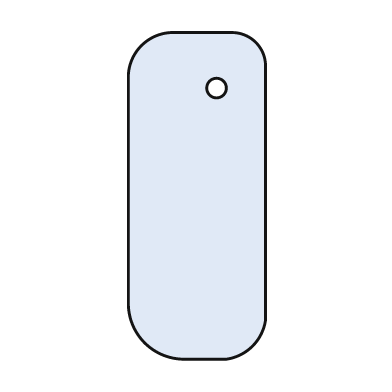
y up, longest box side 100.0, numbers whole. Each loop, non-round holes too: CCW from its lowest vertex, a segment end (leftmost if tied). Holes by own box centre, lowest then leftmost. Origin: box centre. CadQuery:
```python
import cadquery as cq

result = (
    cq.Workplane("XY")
    .moveTo(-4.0, -50.0)
    .lineTo(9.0, -50.0)
    .threePointArc((17.0, -46.0), (21.0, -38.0))
    .lineTo(21.0, 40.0)
    .threePointArc((18.0, 47.0), (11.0, 50.0))
    .lineTo(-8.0, 50.0)
    .threePointArc((-17.0, 46.0), (-21.0, 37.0))
    .lineTo(-21.0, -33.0)
    .threePointArc((-16.0, -45.0), (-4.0, -50.0))
    .close()
    .moveTo(6.0, 33.0)
    .circle(3.0)
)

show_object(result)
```